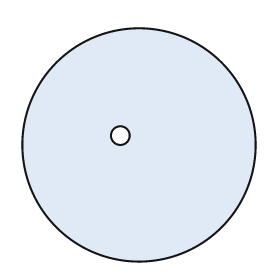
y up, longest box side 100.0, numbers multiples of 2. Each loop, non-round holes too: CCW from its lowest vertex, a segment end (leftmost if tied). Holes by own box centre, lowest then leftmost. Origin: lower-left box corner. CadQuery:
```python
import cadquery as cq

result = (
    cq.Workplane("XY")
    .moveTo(50.0, 50.0)
    .circle(50.0)
    .moveTo(42.0, 54.0)
    .circle(4.0)
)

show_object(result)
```